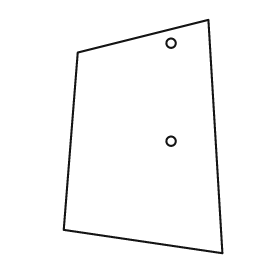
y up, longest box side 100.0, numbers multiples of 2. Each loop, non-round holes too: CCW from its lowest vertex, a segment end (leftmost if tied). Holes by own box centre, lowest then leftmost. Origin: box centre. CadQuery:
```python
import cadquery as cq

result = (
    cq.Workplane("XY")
    .moveTo(34.0, -50.0)
    .lineTo(28.0, 50.0)
    .lineTo(-28.0, 36.0)
    .lineTo(-34.0, -40.0)
    .close()
    .moveTo(12.0, -2.0)
    .circle(2.0)
    .moveTo(12.0, 40.0)
    .circle(2.0)
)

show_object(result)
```